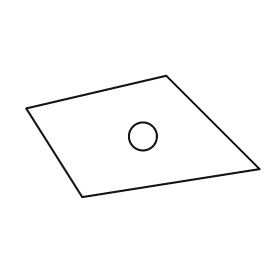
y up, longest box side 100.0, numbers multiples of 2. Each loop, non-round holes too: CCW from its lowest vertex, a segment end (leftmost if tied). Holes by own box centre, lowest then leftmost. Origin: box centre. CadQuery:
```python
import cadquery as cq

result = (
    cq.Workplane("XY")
    .moveTo(-26.0, -26.0)
    .lineTo(50.0, -14.0)
    .lineTo(10.0, 26.0)
    .lineTo(-50.0, 12.0)
    .close()
    .moveTo(0.0, 0.0)
    .circle(6.0)
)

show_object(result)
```